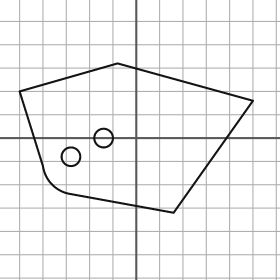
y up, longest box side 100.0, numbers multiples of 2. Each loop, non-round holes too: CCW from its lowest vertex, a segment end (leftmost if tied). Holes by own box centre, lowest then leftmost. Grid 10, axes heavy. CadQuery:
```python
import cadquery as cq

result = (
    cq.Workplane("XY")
    .moveTo(16.0, -32.0)
    .lineTo(50.0, 16.0)
    .lineTo(-8.0, 32.0)
    .lineTo(-50.0, 20.0)
    .lineTo(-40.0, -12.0)
    .threePointArc((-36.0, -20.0), (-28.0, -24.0))
    .close()
    .moveTo(-28.0, -8.0)
    .circle(4.0)
    .moveTo(-14.0, 0.0)
    .circle(4.0)
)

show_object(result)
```